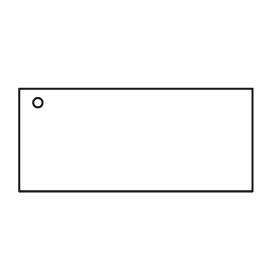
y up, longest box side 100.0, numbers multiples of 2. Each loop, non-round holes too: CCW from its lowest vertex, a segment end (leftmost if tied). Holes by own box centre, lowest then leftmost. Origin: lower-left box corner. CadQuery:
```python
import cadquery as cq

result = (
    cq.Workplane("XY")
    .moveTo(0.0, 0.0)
    .lineTo(100.0, 0.0)
    .lineTo(100.0, 44.0)
    .lineTo(0.0, 44.0)
    .close()
    .moveTo(8.0, 38.0)
    .circle(2.0)
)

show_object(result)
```